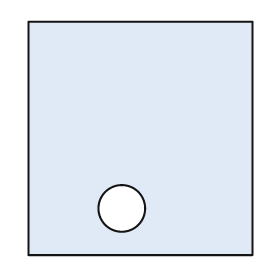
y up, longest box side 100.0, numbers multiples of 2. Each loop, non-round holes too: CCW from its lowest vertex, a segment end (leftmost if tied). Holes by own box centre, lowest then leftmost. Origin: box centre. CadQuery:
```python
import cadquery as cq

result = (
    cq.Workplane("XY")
    .moveTo(-48.0, -50.0)
    .lineTo(48.0, -50.0)
    .lineTo(48.0, 50.0)
    .lineTo(-48.0, 50.0)
    .close()
    .moveTo(-8.0, -30.0)
    .circle(10.0)
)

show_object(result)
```